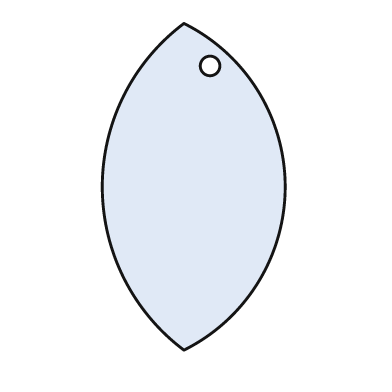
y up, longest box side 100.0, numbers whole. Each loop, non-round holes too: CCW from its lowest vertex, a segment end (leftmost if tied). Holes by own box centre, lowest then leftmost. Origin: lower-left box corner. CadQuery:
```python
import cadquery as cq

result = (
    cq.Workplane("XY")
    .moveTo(25.0, 0.0)
    .threePointArc((56.0, 50.0), (25.0, 100.0))
    .threePointArc((0.0, 50.0), (25.0, 0.0))
    .close()
    .moveTo(33.0, 87.0)
    .circle(3.0)
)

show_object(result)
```